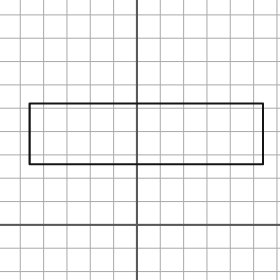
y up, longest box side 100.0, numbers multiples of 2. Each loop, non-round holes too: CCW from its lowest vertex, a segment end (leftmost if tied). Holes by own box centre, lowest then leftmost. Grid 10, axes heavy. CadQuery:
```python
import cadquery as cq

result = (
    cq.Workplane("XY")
    .moveTo(-46.0, 26.0)
    .lineTo(54.0, 26.0)
    .lineTo(54.0, 52.0)
    .lineTo(-46.0, 52.0)
    .close()
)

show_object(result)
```